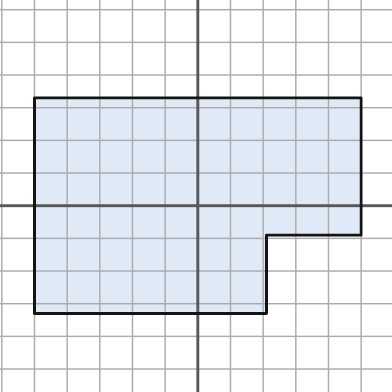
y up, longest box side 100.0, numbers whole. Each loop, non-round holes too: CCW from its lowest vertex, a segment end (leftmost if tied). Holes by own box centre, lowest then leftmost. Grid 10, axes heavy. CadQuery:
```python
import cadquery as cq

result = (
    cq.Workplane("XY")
    .moveTo(-50.0, -33.0)
    .lineTo(21.0, -33.0)
    .lineTo(21.0, -9.0)
    .lineTo(50.0, -9.0)
    .lineTo(50.0, 33.0)
    .lineTo(-50.0, 33.0)
    .close()
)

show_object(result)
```